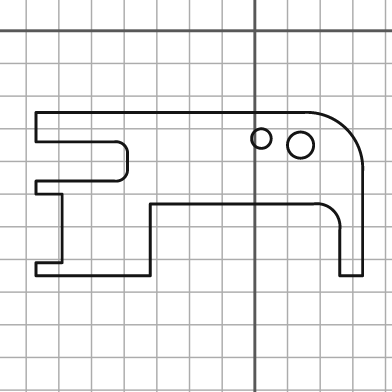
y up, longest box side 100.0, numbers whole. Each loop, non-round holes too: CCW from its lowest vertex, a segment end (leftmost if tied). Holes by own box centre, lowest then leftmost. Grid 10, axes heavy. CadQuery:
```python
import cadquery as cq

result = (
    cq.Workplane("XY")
    .moveTo(-67.0, -75.0)
    .lineTo(-32.0, -75.0)
    .lineTo(-32.0, -53.0)
    .lineTo(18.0, -53.0)
    .threePointArc((24.0, -55.0), (26.0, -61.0))
    .lineTo(26.0, -75.0)
    .lineTo(33.0, -75.0)
    .lineTo(33.0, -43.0)
    .threePointArc((28.0, -30.0), (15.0, -25.0))
    .lineTo(-67.0, -25.0)
    .lineTo(-67.0, -34.0)
    .lineTo(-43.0, -34.0)
    .threePointArc((-40.0, -35.0), (-39.0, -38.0))
    .lineTo(-39.0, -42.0)
    .threePointArc((-40.0, -45.0), (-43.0, -46.0))
    .lineTo(-67.0, -46.0)
    .lineTo(-67.0, -50.0)
    .lineTo(-59.0, -50.0)
    .lineTo(-59.0, -71.0)
    .lineTo(-67.0, -71.0)
    .close()
    .moveTo(14.0, -35.0)
    .circle(4.0)
    .moveTo(2.0, -33.0)
    .circle(3.0)
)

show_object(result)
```